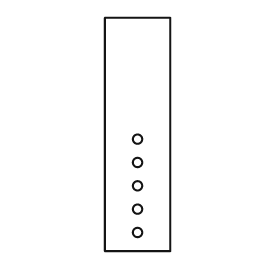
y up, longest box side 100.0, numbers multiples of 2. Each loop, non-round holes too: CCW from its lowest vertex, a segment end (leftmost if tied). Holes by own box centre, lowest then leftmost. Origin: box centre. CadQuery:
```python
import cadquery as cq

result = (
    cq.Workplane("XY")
    .moveTo(-14.0, -50.0)
    .lineTo(14.0, -50.0)
    .lineTo(14.0, 50.0)
    .lineTo(-14.0, 50.0)
    .close()
    .moveTo(0.0, -42.0)
    .circle(2.0)
    .moveTo(0.0, -32.0)
    .circle(2.0)
    .moveTo(0.0, -22.0)
    .circle(2.0)
    .moveTo(0.0, -12.0)
    .circle(2.0)
    .moveTo(0.0, -2.0)
    .circle(2.0)
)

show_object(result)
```